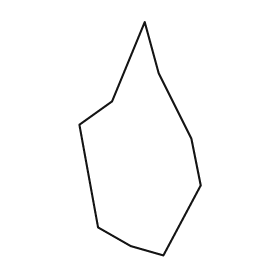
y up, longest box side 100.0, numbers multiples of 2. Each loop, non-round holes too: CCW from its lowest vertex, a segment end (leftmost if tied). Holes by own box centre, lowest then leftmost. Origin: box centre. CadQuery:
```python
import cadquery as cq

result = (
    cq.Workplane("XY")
    .moveTo(10.0, -50.0)
    .lineTo(26.0, -20.0)
    .lineTo(22.0, 0.0)
    .lineTo(8.0, 28.0)
    .lineTo(2.0, 50.0)
    .lineTo(-12.0, 16.0)
    .lineTo(-26.0, 6.0)
    .lineTo(-18.0, -38.0)
    .lineTo(-4.0, -46.0)
    .close()
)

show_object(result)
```